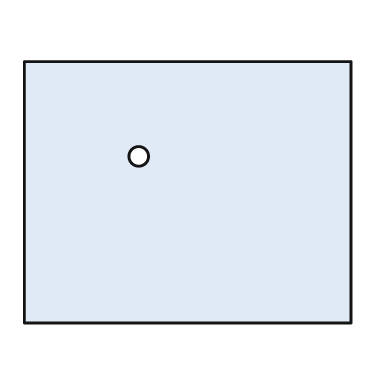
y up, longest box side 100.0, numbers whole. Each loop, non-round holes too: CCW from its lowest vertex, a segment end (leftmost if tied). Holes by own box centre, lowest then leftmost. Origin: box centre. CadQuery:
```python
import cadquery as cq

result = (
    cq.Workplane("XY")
    .moveTo(-50.0, -40.0)
    .lineTo(50.0, -40.0)
    .lineTo(50.0, 40.0)
    .lineTo(-50.0, 40.0)
    .close()
    .moveTo(-15.0, 11.0)
    .circle(3.0)
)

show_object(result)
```